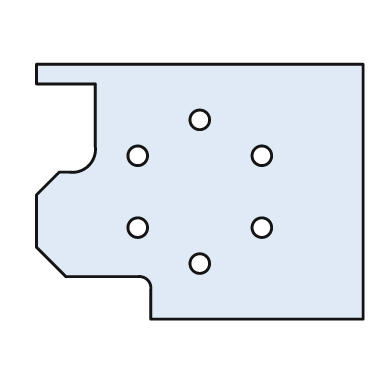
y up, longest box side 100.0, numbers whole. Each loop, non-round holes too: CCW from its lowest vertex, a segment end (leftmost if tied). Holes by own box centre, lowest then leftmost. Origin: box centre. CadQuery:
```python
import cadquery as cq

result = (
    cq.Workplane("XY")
    .moveTo(-15.0, -39.0)
    .lineTo(50.0, -39.0)
    .lineTo(50.0, 39.0)
    .lineTo(-50.0, 39.0)
    .lineTo(-50.0, 33.0)
    .lineTo(-32.0, 33.0)
    .lineTo(-32.0, 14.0)
    .threePointArc((-34.0, 8.0), (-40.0, 6.0))
    .lineTo(-43.0, 6.0)
    .lineTo(-50.0, -1.0)
    .lineTo(-50.0, -17.0)
    .lineTo(-41.0, -26.0)
    .lineTo(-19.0, -26.0)
    .threePointArc((-16.0, -27.0), (-15.0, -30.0))
    .close()
    .moveTo(0.0, -22.0)
    .circle(3.0)
    .moveTo(-19.0, -11.0)
    .circle(3.0)
    .moveTo(19.0, -11.0)
    .circle(3.0)
    .moveTo(-19.0, 11.0)
    .circle(3.0)
    .moveTo(19.0, 11.0)
    .circle(3.0)
    .moveTo(0.0, 22.0)
    .circle(3.0)
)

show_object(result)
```